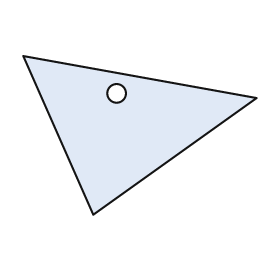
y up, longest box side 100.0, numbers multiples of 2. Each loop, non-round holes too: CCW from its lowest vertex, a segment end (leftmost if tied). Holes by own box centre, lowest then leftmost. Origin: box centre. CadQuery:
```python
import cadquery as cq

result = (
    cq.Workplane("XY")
    .moveTo(-20.0, -34.0)
    .lineTo(50.0, 16.0)
    .lineTo(-50.0, 34.0)
    .close()
    .moveTo(-10.0, 18.0)
    .circle(4.0)
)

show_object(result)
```